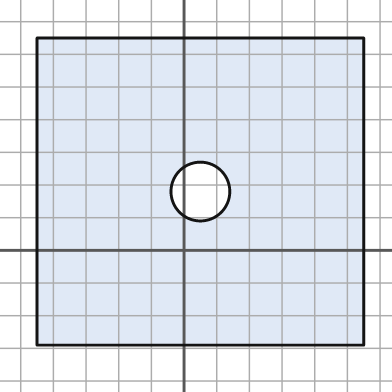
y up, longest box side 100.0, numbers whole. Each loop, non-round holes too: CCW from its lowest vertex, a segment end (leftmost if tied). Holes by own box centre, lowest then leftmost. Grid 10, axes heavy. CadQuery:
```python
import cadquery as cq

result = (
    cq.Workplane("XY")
    .moveTo(-45.0, -29.0)
    .lineTo(55.0, -29.0)
    .lineTo(55.0, 65.0)
    .lineTo(-45.0, 65.0)
    .close()
    .moveTo(5.0, 18.0)
    .circle(9.0)
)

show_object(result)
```